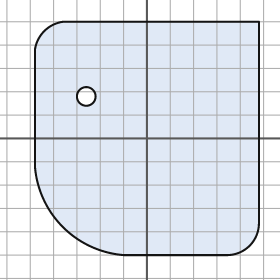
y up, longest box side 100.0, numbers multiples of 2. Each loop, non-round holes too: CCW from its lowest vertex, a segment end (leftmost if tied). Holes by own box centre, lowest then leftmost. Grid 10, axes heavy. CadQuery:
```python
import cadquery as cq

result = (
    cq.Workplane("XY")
    .moveTo(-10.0, -50.0)
    .lineTo(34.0, -50.0)
    .threePointArc((44.0, -46.0), (48.0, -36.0))
    .lineTo(48.0, 50.0)
    .lineTo(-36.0, 50.0)
    .threePointArc((-44.0, 46.0), (-48.0, 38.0))
    .lineTo(-48.0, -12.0)
    .threePointArc((-36.0, -38.0), (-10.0, -50.0))
    .close()
    .moveTo(-26.0, 18.0)
    .circle(4.0)
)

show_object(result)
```